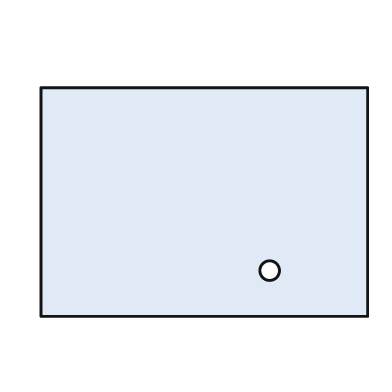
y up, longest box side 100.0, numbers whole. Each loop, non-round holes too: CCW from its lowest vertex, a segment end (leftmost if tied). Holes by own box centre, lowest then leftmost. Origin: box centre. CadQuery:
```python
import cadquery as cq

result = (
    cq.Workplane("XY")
    .moveTo(-50.0, -35.0)
    .lineTo(50.0, -35.0)
    .lineTo(50.0, 35.0)
    .lineTo(-50.0, 35.0)
    .close()
    .moveTo(20.0, -21.0)
    .circle(3.0)
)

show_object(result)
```